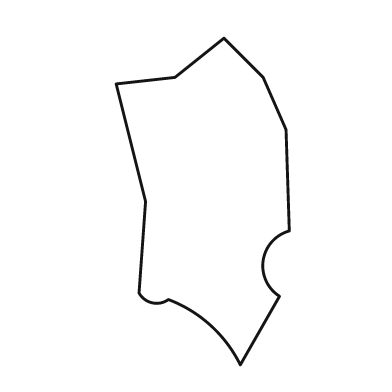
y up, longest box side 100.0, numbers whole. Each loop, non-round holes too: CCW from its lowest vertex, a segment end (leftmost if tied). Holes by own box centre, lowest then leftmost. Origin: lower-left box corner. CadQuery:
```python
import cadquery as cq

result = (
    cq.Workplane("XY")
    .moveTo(38.0, 0.0)
    .lineTo(50.0, 21.0)
    .threePointArc((45.0, 32.0), (53.0, 41.0))
    .lineTo(52.0, 72.0)
    .lineTo(45.0, 88.0)
    .lineTo(33.0, 100.0)
    .lineTo(18.0, 88.0)
    .lineTo(0.0, 86.0)
    .lineTo(9.0, 50.0)
    .lineTo(7.0, 22.0)
    .threePointArc((11.0, 19.0), (16.0, 20.0))
    .threePointArc((29.0, 12.0), (38.0, 0.0))
    .close()
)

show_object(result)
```